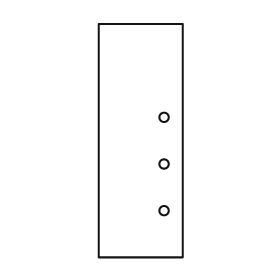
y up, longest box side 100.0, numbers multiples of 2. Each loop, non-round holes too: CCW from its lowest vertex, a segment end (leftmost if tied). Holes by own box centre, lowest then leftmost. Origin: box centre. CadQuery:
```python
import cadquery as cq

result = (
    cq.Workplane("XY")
    .moveTo(-18.0, -50.0)
    .lineTo(18.0, -50.0)
    .lineTo(18.0, 50.0)
    .lineTo(-18.0, 50.0)
    .close()
    .moveTo(10.0, -30.0)
    .circle(2.0)
    .moveTo(10.0, -10.0)
    .circle(2.0)
    .moveTo(10.0, 10.0)
    .circle(2.0)
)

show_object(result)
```